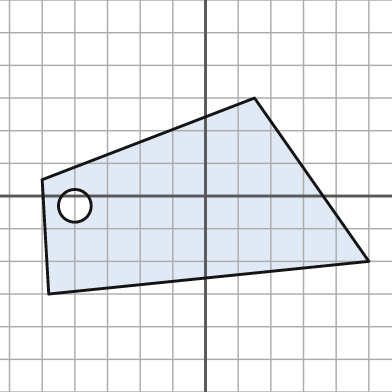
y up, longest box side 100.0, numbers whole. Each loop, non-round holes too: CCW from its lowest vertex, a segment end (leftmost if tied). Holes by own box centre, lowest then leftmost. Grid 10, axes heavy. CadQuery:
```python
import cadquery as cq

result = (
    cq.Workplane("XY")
    .moveTo(-48.0, -30.0)
    .lineTo(50.0, -20.0)
    .lineTo(15.0, 30.0)
    .lineTo(-50.0, 5.0)
    .close()
    .moveTo(-40.0, -3.0)
    .circle(5.0)
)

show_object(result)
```